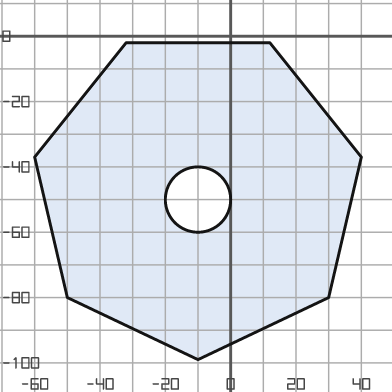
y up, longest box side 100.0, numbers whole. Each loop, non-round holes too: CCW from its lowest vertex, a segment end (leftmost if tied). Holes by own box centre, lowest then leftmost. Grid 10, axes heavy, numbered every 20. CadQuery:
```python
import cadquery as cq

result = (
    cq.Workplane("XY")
    .moveTo(-10.0, -99.0)
    .lineTo(30.0, -80.0)
    .lineTo(40.0, -37.0)
    .lineTo(12.0, -2.0)
    .lineTo(-32.0, -2.0)
    .lineTo(-60.0, -37.0)
    .lineTo(-50.0, -80.0)
    .close()
    .moveTo(-10.0, -50.0)
    .circle(10.0)
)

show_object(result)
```